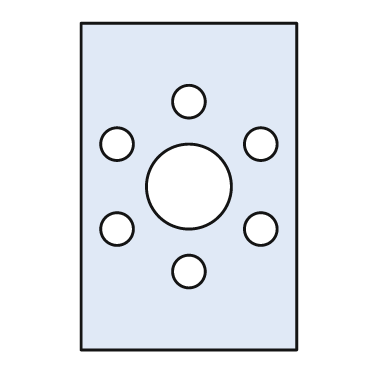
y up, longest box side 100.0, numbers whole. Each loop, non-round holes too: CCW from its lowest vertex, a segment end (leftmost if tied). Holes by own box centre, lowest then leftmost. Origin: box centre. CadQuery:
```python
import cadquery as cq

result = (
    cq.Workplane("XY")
    .moveTo(-33.0, -50.0)
    .lineTo(33.0, -50.0)
    .lineTo(33.0, 50.0)
    .lineTo(-33.0, 50.0)
    .close()
    .moveTo(0.0, -26.0)
    .circle(5.0)
    .moveTo(-22.0, -13.0)
    .circle(5.0)
    .moveTo(22.0, -13.0)
    .circle(5.0)
    .moveTo(0.0, 0.0)
    .circle(13.0)
    .moveTo(-22.0, 13.0)
    .circle(5.0)
    .moveTo(22.0, 13.0)
    .circle(5.0)
    .moveTo(0.0, 26.0)
    .circle(5.0)
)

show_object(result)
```